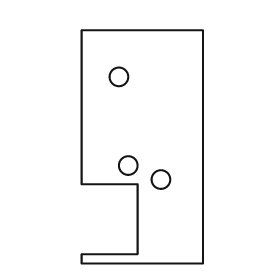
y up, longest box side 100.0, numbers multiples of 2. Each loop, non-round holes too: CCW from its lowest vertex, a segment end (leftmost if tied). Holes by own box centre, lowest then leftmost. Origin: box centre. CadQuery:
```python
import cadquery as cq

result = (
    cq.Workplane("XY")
    .moveTo(-26.0, -50.0)
    .lineTo(26.0, -50.0)
    .lineTo(26.0, 50.0)
    .lineTo(-26.0, 50.0)
    .lineTo(-26.0, -16.0)
    .lineTo(-2.0, -16.0)
    .lineTo(-2.0, -46.0)
    .lineTo(-26.0, -46.0)
    .close()
    .moveTo(8.0, -14.0)
    .circle(4.0)
    .moveTo(-6.0, -8.0)
    .circle(4.0)
    .moveTo(-10.0, 30.0)
    .circle(4.0)
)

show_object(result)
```